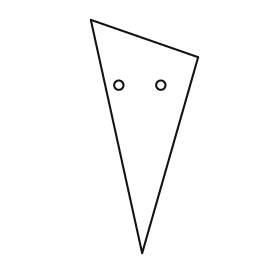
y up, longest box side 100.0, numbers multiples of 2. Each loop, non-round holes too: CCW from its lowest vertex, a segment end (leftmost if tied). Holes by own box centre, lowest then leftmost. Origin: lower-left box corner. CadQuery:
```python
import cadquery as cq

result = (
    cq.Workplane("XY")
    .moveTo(22.0, 0.0)
    .lineTo(46.0, 84.0)
    .lineTo(0.0, 100.0)
    .close()
    .moveTo(12.0, 72.0)
    .circle(2.0)
    .moveTo(30.0, 72.0)
    .circle(2.0)
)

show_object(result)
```